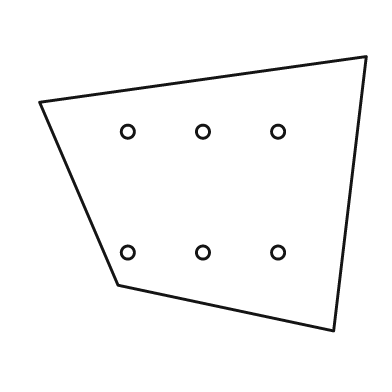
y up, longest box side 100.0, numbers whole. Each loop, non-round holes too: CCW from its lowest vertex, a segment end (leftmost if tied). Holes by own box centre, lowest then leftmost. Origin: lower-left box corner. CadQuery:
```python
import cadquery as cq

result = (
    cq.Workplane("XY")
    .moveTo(90.0, 0.0)
    .lineTo(100.0, 84.0)
    .lineTo(0.0, 70.0)
    .lineTo(24.0, 14.0)
    .close()
    .moveTo(27.0, 24.0)
    .circle(2.0)
    .moveTo(50.0, 24.0)
    .circle(2.0)
    .moveTo(73.0, 24.0)
    .circle(2.0)
    .moveTo(27.0, 61.0)
    .circle(2.0)
    .moveTo(50.0, 61.0)
    .circle(2.0)
    .moveTo(73.0, 61.0)
    .circle(2.0)
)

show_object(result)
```